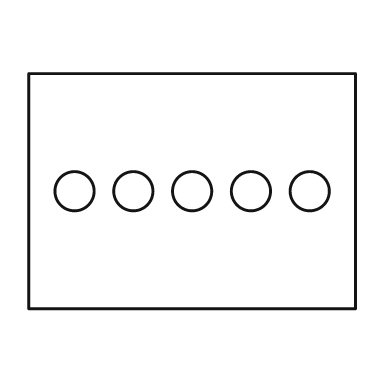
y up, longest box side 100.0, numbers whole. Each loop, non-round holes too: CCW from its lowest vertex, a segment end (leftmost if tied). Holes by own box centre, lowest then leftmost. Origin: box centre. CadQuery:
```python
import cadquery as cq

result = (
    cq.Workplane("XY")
    .moveTo(-50.0, -36.0)
    .lineTo(50.0, -36.0)
    .lineTo(50.0, 36.0)
    .lineTo(-50.0, 36.0)
    .close()
    .moveTo(-36.0, 0.0)
    .circle(6.0)
    .moveTo(-18.0, 0.0)
    .circle(6.0)
    .moveTo(0.0, 0.0)
    .circle(6.0)
    .moveTo(18.0, 0.0)
    .circle(6.0)
    .moveTo(36.0, 0.0)
    .circle(6.0)
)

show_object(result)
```